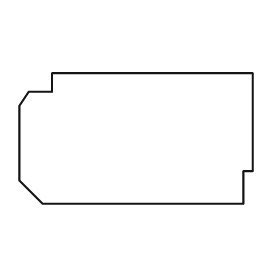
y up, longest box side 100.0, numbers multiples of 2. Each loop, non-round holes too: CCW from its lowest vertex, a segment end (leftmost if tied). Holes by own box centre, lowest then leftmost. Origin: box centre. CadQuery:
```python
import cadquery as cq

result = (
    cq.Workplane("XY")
    .moveTo(-40.0, -28.0)
    .lineTo(46.0, -28.0)
    .lineTo(46.0, -14.0)
    .lineTo(50.0, -14.0)
    .lineTo(50.0, 28.0)
    .lineTo(-36.0, 28.0)
    .lineTo(-36.0, 20.0)
    .lineTo(-46.0, 20.0)
    .lineTo(-50.0, 14.0)
    .lineTo(-50.0, -18.0)
    .close()
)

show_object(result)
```